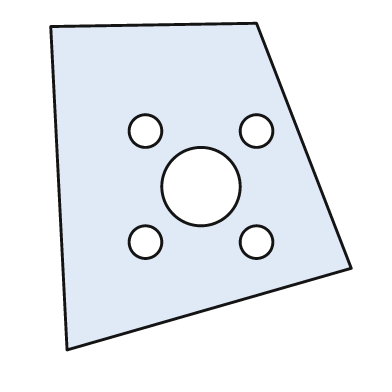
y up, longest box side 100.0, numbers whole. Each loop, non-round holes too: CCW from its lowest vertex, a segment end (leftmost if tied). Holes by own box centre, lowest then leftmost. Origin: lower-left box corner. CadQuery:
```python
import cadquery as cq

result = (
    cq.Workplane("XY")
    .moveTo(5.0, 0.0)
    .lineTo(92.0, 25.0)
    .lineTo(63.0, 100.0)
    .lineTo(0.0, 99.0)
    .close()
    .moveTo(29.0, 33.0)
    .circle(5.0)
    .moveTo(63.0, 33.0)
    .circle(5.0)
    .moveTo(46.0, 50.0)
    .circle(12.0)
    .moveTo(29.0, 67.0)
    .circle(5.0)
    .moveTo(63.0, 67.0)
    .circle(5.0)
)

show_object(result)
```